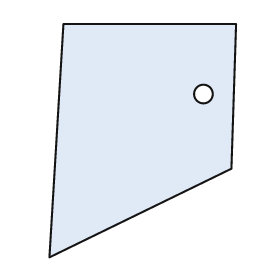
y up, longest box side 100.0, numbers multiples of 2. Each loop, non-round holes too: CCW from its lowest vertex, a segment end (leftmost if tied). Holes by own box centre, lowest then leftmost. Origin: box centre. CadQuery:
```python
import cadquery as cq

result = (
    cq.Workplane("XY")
    .moveTo(-40.0, -50.0)
    .lineTo(38.0, -12.0)
    .lineTo(40.0, 50.0)
    .lineTo(-34.0, 50.0)
    .close()
    .moveTo(26.0, 20.0)
    .circle(4.0)
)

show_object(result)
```